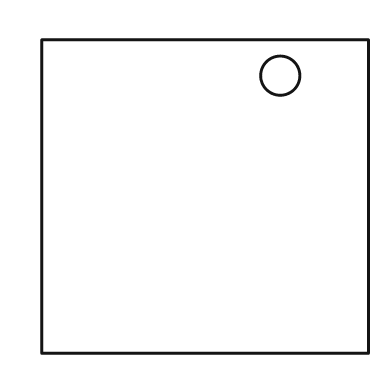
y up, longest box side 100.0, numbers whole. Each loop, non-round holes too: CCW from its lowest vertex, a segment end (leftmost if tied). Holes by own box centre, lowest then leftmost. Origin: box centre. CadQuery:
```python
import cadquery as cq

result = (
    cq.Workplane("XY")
    .moveTo(-50.0, -48.0)
    .lineTo(50.0, -48.0)
    .lineTo(50.0, 48.0)
    .lineTo(-50.0, 48.0)
    .close()
    .moveTo(23.0, 37.0)
    .circle(6.0)
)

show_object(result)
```